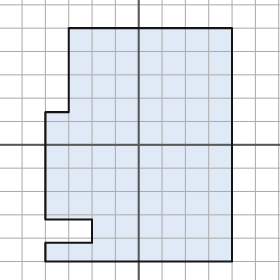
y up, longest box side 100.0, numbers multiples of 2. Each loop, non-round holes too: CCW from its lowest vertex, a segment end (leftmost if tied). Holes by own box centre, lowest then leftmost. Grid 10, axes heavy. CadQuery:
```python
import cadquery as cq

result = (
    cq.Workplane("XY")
    .moveTo(-40.0, -50.0)
    .lineTo(40.0, -50.0)
    .lineTo(40.0, 50.0)
    .lineTo(-30.0, 50.0)
    .lineTo(-30.0, 14.0)
    .lineTo(-40.0, 14.0)
    .lineTo(-40.0, -32.0)
    .lineTo(-20.0, -32.0)
    .lineTo(-20.0, -42.0)
    .lineTo(-40.0, -42.0)
    .close()
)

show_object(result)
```